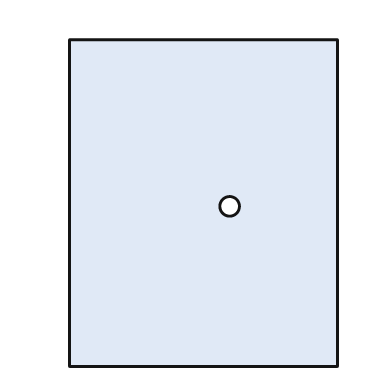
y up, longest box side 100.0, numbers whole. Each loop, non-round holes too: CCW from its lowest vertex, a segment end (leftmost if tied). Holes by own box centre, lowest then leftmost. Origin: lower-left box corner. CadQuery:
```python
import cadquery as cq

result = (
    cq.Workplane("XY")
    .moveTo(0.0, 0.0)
    .lineTo(82.0, 0.0)
    .lineTo(82.0, 100.0)
    .lineTo(0.0, 100.0)
    .close()
    .moveTo(49.0, 49.0)
    .circle(3.0)
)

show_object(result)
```